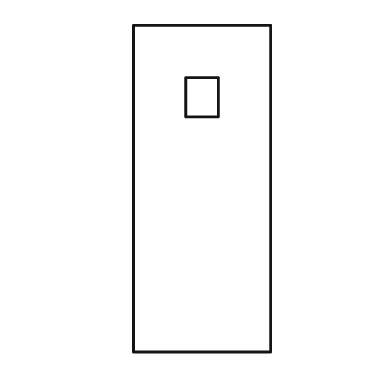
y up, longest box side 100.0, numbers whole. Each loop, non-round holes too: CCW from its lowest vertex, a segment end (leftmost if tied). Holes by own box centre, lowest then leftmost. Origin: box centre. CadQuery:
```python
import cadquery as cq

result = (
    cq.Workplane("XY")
    .moveTo(-21.0, -50.0)
    .lineTo(21.0, -50.0)
    .lineTo(21.0, 50.0)
    .lineTo(-21.0, 50.0)
    .close()
    .moveTo(-5.0, 22.0)
    .lineTo(5.0, 22.0)
    .lineTo(5.0, 34.0)
    .lineTo(-5.0, 34.0)
    .close()
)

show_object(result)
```